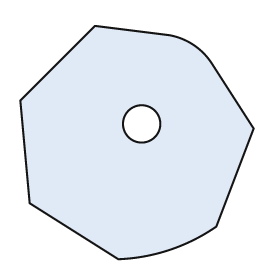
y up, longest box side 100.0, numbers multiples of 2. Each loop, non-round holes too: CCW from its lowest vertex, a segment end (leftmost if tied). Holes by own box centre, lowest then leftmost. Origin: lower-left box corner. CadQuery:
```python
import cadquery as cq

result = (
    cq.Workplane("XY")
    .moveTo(42.0, 0.0)
    .threePointArc((64.0, 4.0), (84.0, 14.0))
    .lineTo(100.0, 56.0)
    .lineTo(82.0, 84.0)
    .threePointArc((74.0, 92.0), (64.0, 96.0))
    .lineTo(32.0, 100.0)
    .lineTo(0.0, 68.0)
    .lineTo(4.0, 24.0)
    .close()
    .moveTo(52.0, 58.0)
    .circle(8.0)
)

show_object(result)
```